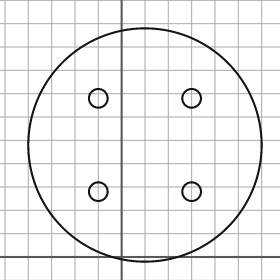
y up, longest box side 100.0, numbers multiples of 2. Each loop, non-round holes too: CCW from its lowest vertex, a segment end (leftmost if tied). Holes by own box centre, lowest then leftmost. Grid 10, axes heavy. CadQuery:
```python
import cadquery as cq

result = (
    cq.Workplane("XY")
    .moveTo(10.0, 48.0)
    .circle(50.0)
    .moveTo(-10.0, 28.0)
    .circle(4.0)
    .moveTo(30.0, 28.0)
    .circle(4.0)
    .moveTo(-10.0, 68.0)
    .circle(4.0)
    .moveTo(30.0, 68.0)
    .circle(4.0)
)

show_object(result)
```